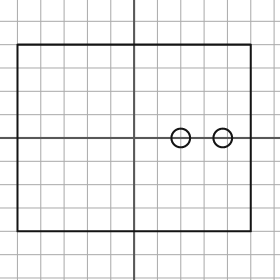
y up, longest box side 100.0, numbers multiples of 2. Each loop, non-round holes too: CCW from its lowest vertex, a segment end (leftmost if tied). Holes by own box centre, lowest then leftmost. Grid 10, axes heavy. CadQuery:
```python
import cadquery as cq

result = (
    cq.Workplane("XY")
    .moveTo(-50.0, -40.0)
    .lineTo(50.0, -40.0)
    .lineTo(50.0, 40.0)
    .lineTo(-50.0, 40.0)
    .close()
    .moveTo(20.0, 0.0)
    .circle(4.0)
    .moveTo(38.0, 0.0)
    .circle(4.0)
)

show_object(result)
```